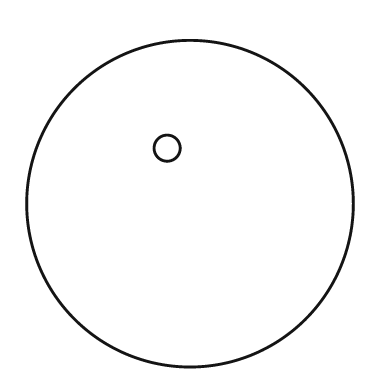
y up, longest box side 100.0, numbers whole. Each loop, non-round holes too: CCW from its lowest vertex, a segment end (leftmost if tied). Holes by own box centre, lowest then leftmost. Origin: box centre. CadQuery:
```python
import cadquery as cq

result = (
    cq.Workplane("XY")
    .moveTo(0.0, 0.0)
    .circle(50.0)
    .moveTo(-7.0, 17.0)
    .circle(4.0)
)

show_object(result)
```